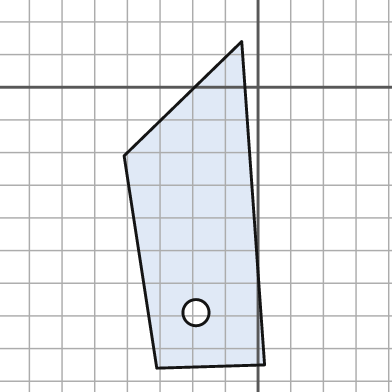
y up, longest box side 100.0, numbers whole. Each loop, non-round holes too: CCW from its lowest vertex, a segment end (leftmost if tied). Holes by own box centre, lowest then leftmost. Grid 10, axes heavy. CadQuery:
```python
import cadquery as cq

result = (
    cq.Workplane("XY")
    .moveTo(-31.0, -86.0)
    .lineTo(2.0, -85.0)
    .lineTo(-5.0, 14.0)
    .lineTo(-41.0, -21.0)
    .close()
    .moveTo(-19.0, -69.0)
    .circle(4.0)
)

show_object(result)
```